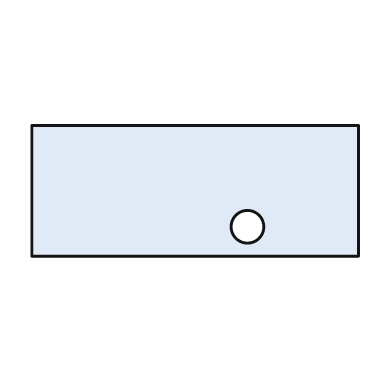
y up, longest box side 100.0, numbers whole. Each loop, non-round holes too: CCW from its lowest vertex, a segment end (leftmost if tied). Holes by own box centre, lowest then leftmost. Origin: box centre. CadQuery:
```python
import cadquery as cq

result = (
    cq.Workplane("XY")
    .moveTo(-50.0, -20.0)
    .lineTo(50.0, -20.0)
    .lineTo(50.0, 20.0)
    .lineTo(-50.0, 20.0)
    .close()
    .moveTo(16.0, -11.0)
    .circle(5.0)
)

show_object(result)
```